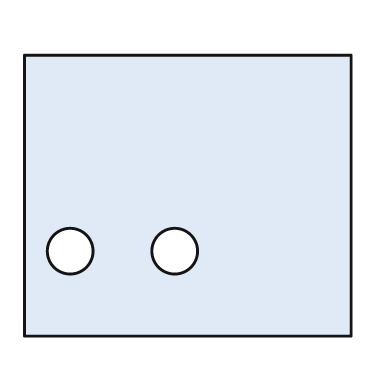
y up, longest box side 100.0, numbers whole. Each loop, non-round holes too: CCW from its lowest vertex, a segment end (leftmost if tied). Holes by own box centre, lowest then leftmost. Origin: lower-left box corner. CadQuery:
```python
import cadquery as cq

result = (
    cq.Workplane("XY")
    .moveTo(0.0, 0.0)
    .lineTo(100.0, 0.0)
    .lineTo(100.0, 86.0)
    .lineTo(0.0, 86.0)
    .close()
    .moveTo(14.0, 26.0)
    .circle(7.0)
    .moveTo(46.0, 26.0)
    .circle(7.0)
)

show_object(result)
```